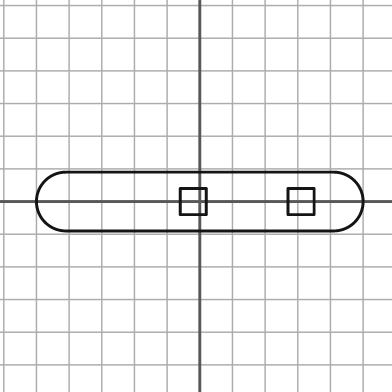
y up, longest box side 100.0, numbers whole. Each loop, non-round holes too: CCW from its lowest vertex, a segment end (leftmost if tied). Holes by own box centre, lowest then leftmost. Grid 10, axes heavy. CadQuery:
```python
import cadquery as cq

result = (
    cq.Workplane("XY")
    .moveTo(-41.0, -9.0)
    .lineTo(41.0, -9.0)
    .threePointArc((50.0, 0.0), (41.0, 9.0))
    .lineTo(-41.0, 9.0)
    .threePointArc((-50.0, 0.0), (-41.0, -9.0))
    .close()
    .moveTo(-6.0, -4.0)
    .lineTo(2.0, -4.0)
    .lineTo(2.0, 4.0)
    .lineTo(-6.0, 4.0)
    .close()
    .moveTo(27.0, -4.0)
    .lineTo(35.0, -4.0)
    .lineTo(35.0, 4.0)
    .lineTo(27.0, 4.0)
    .close()
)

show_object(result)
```